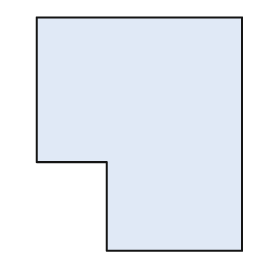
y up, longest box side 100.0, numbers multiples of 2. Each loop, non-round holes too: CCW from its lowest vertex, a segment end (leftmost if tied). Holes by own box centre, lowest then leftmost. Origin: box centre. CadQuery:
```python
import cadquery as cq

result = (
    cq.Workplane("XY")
    .moveTo(-14.0, -50.0)
    .lineTo(44.0, -50.0)
    .lineTo(44.0, 50.0)
    .lineTo(-44.0, 50.0)
    .lineTo(-44.0, -12.0)
    .lineTo(-14.0, -12.0)
    .close()
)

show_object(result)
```